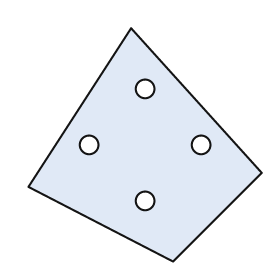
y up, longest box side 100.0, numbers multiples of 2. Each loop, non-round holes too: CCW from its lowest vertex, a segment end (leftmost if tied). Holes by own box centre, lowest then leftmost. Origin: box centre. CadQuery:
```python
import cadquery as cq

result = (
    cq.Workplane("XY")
    .moveTo(12.0, -50.0)
    .lineTo(50.0, -12.0)
    .lineTo(-6.0, 50.0)
    .lineTo(-50.0, -18.0)
    .close()
    .moveTo(0.0, -24.0)
    .circle(4.0)
    .moveTo(-24.0, 0.0)
    .circle(4.0)
    .moveTo(24.0, 0.0)
    .circle(4.0)
    .moveTo(0.0, 24.0)
    .circle(4.0)
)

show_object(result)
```